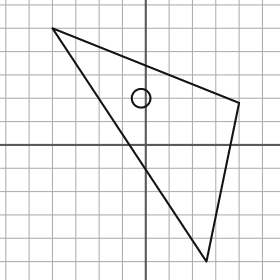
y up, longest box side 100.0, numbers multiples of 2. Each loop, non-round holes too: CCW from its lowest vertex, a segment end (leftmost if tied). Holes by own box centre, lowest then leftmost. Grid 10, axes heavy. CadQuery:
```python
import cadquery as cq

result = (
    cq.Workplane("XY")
    .moveTo(26.0, -50.0)
    .lineTo(40.0, 18.0)
    .lineTo(-40.0, 50.0)
    .close()
    .moveTo(-2.0, 20.0)
    .circle(4.0)
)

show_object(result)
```